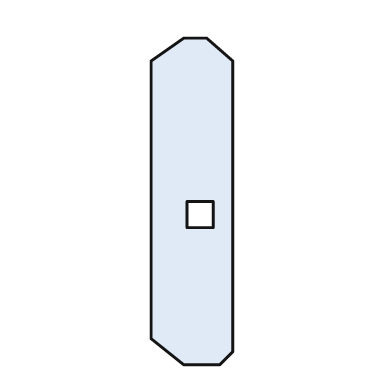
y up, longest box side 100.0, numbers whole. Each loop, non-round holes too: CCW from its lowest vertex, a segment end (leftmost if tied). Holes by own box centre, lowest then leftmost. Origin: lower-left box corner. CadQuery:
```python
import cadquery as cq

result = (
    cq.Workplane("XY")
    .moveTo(10.0, 0.0)
    .lineTo(21.0, 0.0)
    .lineTo(25.0, 4.0)
    .lineTo(25.0, 93.0)
    .lineTo(17.0, 100.0)
    .lineTo(10.0, 100.0)
    .lineTo(0.0, 93.0)
    .lineTo(0.0, 8.0)
    .close()
    .moveTo(11.0, 42.0)
    .lineTo(19.0, 42.0)
    .lineTo(19.0, 50.0)
    .lineTo(11.0, 50.0)
    .close()
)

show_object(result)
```